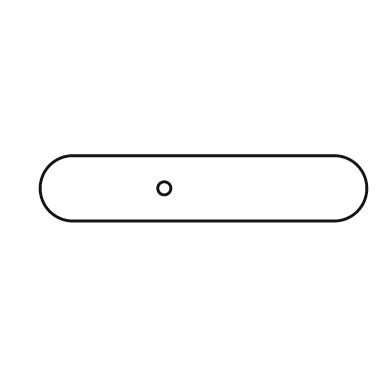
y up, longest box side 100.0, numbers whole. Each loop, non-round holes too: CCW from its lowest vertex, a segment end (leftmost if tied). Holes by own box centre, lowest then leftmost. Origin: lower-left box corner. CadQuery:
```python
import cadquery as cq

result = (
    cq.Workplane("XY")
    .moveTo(10.0, 0.0)
    .lineTo(90.0, 0.0)
    .threePointArc((100.0, 10.0), (90.0, 20.0))
    .lineTo(10.0, 20.0)
    .threePointArc((0.0, 10.0), (10.0, 0.0))
    .close()
    .moveTo(38.0, 10.0)
    .circle(2.0)
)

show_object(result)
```